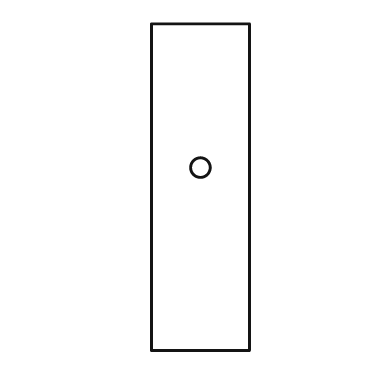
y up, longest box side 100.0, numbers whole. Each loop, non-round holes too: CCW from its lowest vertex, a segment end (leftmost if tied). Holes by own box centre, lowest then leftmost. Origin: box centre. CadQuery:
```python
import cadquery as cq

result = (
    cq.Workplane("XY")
    .moveTo(-15.0, -50.0)
    .lineTo(15.0, -50.0)
    .lineTo(15.0, 50.0)
    .lineTo(-15.0, 50.0)
    .close()
    .moveTo(0.0, 6.0)
    .circle(3.0)
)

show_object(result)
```